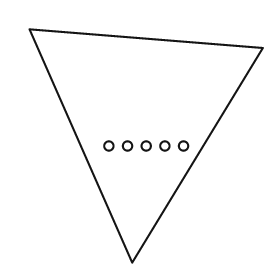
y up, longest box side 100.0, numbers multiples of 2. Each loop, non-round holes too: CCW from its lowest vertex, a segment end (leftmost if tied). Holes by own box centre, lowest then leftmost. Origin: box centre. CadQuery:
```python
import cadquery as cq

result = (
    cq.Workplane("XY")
    .moveTo(-6.0, -50.0)
    .lineTo(50.0, 42.0)
    .lineTo(-50.0, 50.0)
    .close()
    .moveTo(-16.0, 0.0)
    .circle(2.0)
    .moveTo(-8.0, 0.0)
    .circle(2.0)
    .moveTo(0.0, 0.0)
    .circle(2.0)
    .moveTo(8.0, 0.0)
    .circle(2.0)
    .moveTo(16.0, 0.0)
    .circle(2.0)
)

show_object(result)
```